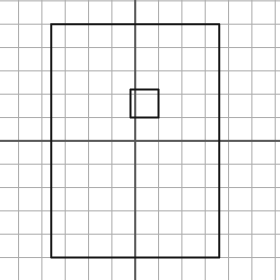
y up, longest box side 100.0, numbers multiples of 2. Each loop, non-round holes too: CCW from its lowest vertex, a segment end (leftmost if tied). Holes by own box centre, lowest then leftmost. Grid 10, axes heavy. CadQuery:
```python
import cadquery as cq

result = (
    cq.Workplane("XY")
    .moveTo(-36.0, -50.0)
    .lineTo(36.0, -50.0)
    .lineTo(36.0, 50.0)
    .lineTo(-36.0, 50.0)
    .close()
    .moveTo(-2.0, 10.0)
    .lineTo(10.0, 10.0)
    .lineTo(10.0, 22.0)
    .lineTo(-2.0, 22.0)
    .close()
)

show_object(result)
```